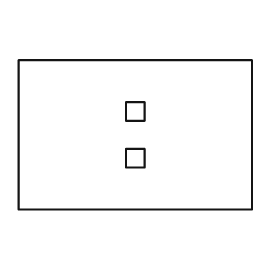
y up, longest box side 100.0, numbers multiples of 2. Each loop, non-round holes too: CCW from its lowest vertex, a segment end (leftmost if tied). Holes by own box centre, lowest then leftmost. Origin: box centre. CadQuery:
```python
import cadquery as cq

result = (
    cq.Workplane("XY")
    .moveTo(-50.0, -32.0)
    .lineTo(50.0, -32.0)
    .lineTo(50.0, 32.0)
    .lineTo(-50.0, 32.0)
    .close()
    .moveTo(-4.0, -14.0)
    .lineTo(4.0, -14.0)
    .lineTo(4.0, -6.0)
    .lineTo(-4.0, -6.0)
    .close()
    .moveTo(-4.0, 6.0)
    .lineTo(4.0, 6.0)
    .lineTo(4.0, 14.0)
    .lineTo(-4.0, 14.0)
    .close()
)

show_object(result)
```